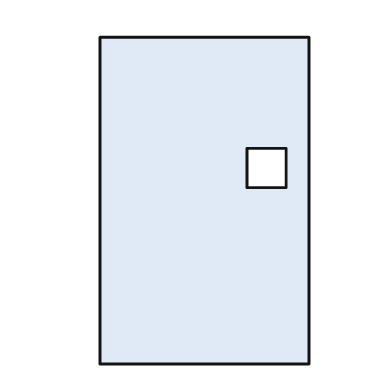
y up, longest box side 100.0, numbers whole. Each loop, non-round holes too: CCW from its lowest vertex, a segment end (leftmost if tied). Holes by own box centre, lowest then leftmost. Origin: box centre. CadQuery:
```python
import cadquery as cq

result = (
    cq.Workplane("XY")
    .moveTo(-32.0, -50.0)
    .lineTo(32.0, -50.0)
    .lineTo(32.0, 50.0)
    .lineTo(-32.0, 50.0)
    .close()
    .moveTo(13.0, 4.0)
    .lineTo(25.0, 4.0)
    .lineTo(25.0, 16.0)
    .lineTo(13.0, 16.0)
    .close()
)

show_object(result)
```